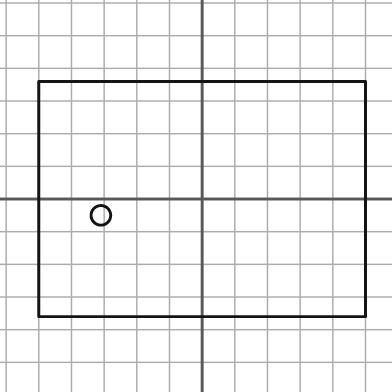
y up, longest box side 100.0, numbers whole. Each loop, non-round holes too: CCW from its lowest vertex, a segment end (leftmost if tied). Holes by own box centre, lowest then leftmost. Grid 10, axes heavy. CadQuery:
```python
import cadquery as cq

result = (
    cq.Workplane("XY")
    .moveTo(-50.0, -36.0)
    .lineTo(50.0, -36.0)
    .lineTo(50.0, 36.0)
    .lineTo(-50.0, 36.0)
    .close()
    .moveTo(-31.0, -5.0)
    .circle(3.0)
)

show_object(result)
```